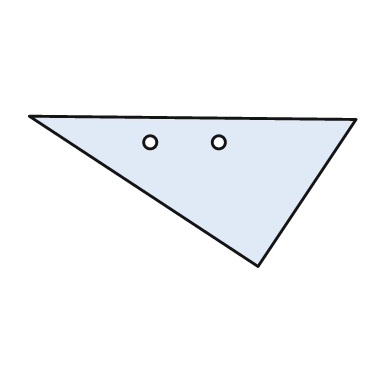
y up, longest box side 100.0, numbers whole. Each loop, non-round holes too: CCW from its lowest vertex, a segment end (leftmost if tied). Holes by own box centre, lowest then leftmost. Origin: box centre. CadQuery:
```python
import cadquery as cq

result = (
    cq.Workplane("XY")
    .moveTo(20.0, -23.0)
    .lineTo(50.0, 22.0)
    .lineTo(-50.0, 23.0)
    .close()
    .moveTo(-13.0, 15.0)
    .circle(2.0)
    .moveTo(8.0, 15.0)
    .circle(2.0)
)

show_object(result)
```